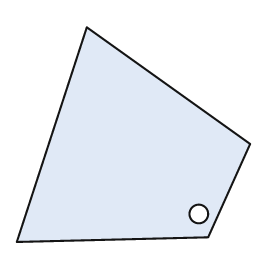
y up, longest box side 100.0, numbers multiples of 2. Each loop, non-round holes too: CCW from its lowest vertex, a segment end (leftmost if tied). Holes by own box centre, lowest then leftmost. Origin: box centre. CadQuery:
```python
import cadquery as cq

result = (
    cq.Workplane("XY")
    .moveTo(-50.0, -46.0)
    .lineTo(32.0, -44.0)
    .lineTo(50.0, -4.0)
    .lineTo(-20.0, 46.0)
    .close()
    .moveTo(28.0, -34.0)
    .circle(4.0)
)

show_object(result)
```